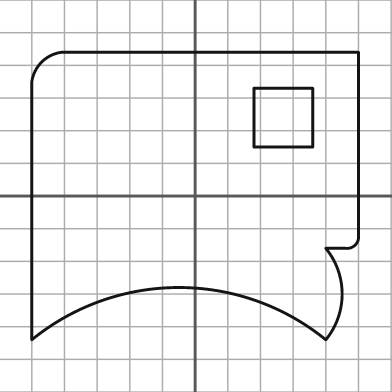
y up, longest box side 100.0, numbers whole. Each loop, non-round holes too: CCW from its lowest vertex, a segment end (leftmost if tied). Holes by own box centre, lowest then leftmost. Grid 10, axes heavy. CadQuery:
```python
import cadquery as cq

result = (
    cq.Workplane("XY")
    .moveTo(-50.0, -44.0)
    .threePointArc((-5.0, -28.0), (40.0, -44.0))
    .threePointArc((45.0, -30.0), (40.0, -16.0))
    .lineTo(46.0, -16.0)
    .threePointArc((49.0, -15.0), (50.0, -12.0))
    .lineTo(50.0, 44.0)
    .lineTo(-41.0, 44.0)
    .threePointArc((-47.0, 41.0), (-50.0, 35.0))
    .close()
    .moveTo(18.0, 15.0)
    .lineTo(36.0, 15.0)
    .lineTo(36.0, 33.0)
    .lineTo(18.0, 33.0)
    .close()
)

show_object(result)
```